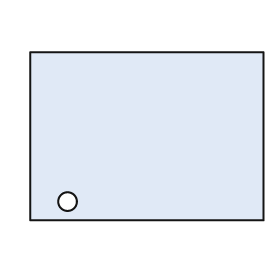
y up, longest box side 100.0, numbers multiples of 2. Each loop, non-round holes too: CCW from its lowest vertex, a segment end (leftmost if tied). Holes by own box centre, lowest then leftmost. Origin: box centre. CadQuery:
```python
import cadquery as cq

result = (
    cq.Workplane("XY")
    .moveTo(-50.0, -36.0)
    .lineTo(50.0, -36.0)
    .lineTo(50.0, 36.0)
    .lineTo(-50.0, 36.0)
    .close()
    .moveTo(-34.0, -28.0)
    .circle(4.0)
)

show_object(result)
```